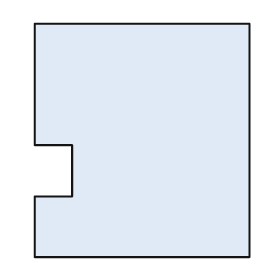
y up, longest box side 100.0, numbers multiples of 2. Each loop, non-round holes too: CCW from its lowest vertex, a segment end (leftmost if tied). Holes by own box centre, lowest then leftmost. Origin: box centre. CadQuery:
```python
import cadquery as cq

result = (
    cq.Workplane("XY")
    .moveTo(-46.0, -50.0)
    .lineTo(46.0, -50.0)
    .lineTo(46.0, 50.0)
    .lineTo(-46.0, 50.0)
    .lineTo(-46.0, -2.0)
    .lineTo(-30.0, -2.0)
    .lineTo(-30.0, -24.0)
    .lineTo(-46.0, -24.0)
    .close()
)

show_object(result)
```